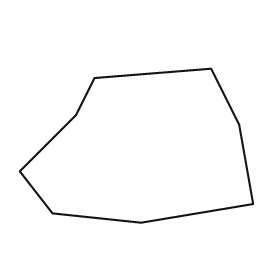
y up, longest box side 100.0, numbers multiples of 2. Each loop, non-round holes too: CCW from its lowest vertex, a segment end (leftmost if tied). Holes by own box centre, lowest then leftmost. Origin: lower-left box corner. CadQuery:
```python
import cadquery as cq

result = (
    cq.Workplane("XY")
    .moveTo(52.0, 0.0)
    .lineTo(100.0, 8.0)
    .lineTo(94.0, 42.0)
    .lineTo(82.0, 66.0)
    .lineTo(32.0, 62.0)
    .lineTo(24.0, 46.0)
    .lineTo(0.0, 22.0)
    .lineTo(14.0, 4.0)
    .close()
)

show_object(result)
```